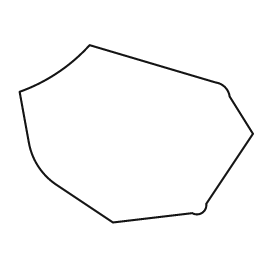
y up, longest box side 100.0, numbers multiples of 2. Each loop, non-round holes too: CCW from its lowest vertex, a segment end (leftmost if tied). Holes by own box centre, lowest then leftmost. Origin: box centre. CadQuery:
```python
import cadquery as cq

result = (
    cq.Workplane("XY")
    .moveTo(-10.0, -38.0)
    .lineTo(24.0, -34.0)
    .threePointArc((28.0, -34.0), (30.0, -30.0))
    .lineTo(50.0, 0.0)
    .lineTo(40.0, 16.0)
    .threePointArc((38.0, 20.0), (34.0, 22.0))
    .lineTo(-20.0, 38.0)
    .threePointArc((-34.0, 26.0), (-50.0, 18.0))
    .lineTo(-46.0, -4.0)
    .threePointArc((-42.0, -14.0), (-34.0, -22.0))
    .close()
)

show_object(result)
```